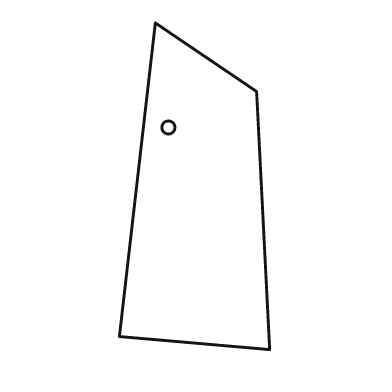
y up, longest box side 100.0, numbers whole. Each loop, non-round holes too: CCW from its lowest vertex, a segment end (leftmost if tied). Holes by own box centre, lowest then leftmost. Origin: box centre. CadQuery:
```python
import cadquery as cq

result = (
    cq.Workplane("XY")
    .moveTo(23.0, -50.0)
    .lineTo(19.0, 29.0)
    .lineTo(-12.0, 50.0)
    .lineTo(-23.0, -46.0)
    .close()
    .moveTo(-8.0, 18.0)
    .circle(2.0)
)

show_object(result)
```